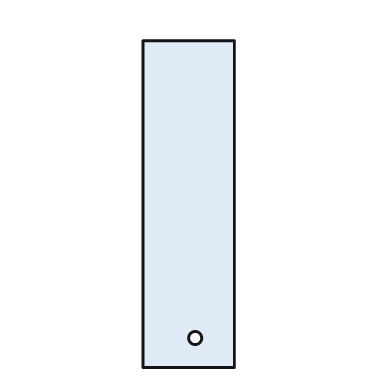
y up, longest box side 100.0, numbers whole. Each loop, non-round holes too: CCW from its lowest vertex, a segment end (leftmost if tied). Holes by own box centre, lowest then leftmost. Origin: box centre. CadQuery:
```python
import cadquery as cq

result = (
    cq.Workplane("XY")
    .moveTo(-14.0, -50.0)
    .lineTo(14.0, -50.0)
    .lineTo(14.0, 50.0)
    .lineTo(-14.0, 50.0)
    .close()
    .moveTo(2.0, -41.0)
    .circle(2.0)
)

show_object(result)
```